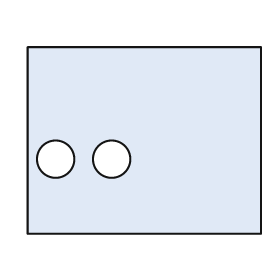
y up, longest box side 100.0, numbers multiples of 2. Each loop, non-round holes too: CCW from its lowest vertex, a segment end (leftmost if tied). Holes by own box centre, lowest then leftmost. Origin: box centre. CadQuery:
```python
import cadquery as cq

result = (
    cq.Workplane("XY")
    .moveTo(-50.0, -40.0)
    .lineTo(50.0, -40.0)
    .lineTo(50.0, 40.0)
    .lineTo(-50.0, 40.0)
    .close()
    .moveTo(-38.0, -8.0)
    .circle(8.0)
    .moveTo(-14.0, -8.0)
    .circle(8.0)
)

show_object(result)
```